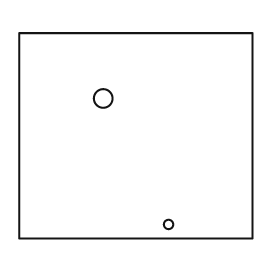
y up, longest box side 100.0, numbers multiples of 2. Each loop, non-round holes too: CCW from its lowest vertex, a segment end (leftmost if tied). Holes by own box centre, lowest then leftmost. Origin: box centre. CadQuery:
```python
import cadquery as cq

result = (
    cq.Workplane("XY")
    .moveTo(-50.0, -44.0)
    .lineTo(50.0, -44.0)
    .lineTo(50.0, 44.0)
    .lineTo(-50.0, 44.0)
    .close()
    .moveTo(14.0, -38.0)
    .circle(2.0)
    .moveTo(-14.0, 16.0)
    .circle(4.0)
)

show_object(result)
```